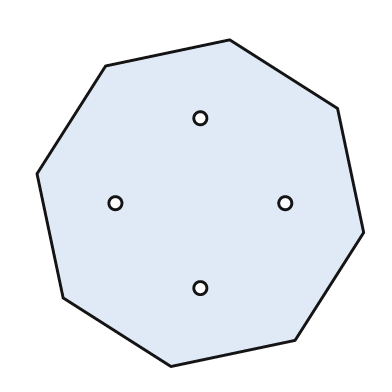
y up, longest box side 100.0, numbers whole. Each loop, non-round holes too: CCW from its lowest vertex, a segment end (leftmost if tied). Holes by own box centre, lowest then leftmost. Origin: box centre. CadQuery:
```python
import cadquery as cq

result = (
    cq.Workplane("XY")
    .moveTo(-9.0, -50.0)
    .lineTo(29.0, -42.0)
    .lineTo(50.0, -9.0)
    .lineTo(42.0, 29.0)
    .lineTo(9.0, 50.0)
    .lineTo(-29.0, 42.0)
    .lineTo(-50.0, 9.0)
    .lineTo(-42.0, -29.0)
    .close()
    .moveTo(0.0, -26.0)
    .circle(2.0)
    .moveTo(-26.0, 0.0)
    .circle(2.0)
    .moveTo(26.0, 0.0)
    .circle(2.0)
    .moveTo(0.0, 26.0)
    .circle(2.0)
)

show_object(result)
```